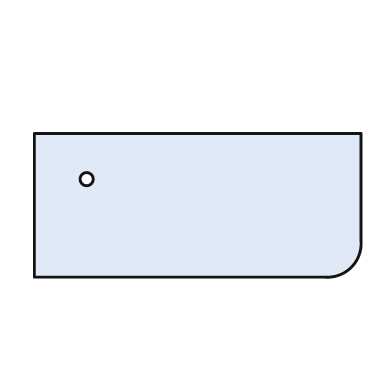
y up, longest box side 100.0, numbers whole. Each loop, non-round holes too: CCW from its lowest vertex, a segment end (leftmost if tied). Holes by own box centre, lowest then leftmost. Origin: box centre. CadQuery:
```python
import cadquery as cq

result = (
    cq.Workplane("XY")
    .moveTo(-50.0, -22.0)
    .lineTo(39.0, -22.0)
    .threePointArc((47.0, -19.0), (50.0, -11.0))
    .lineTo(50.0, 22.0)
    .lineTo(-50.0, 22.0)
    .close()
    .moveTo(-34.0, 8.0)
    .circle(2.0)
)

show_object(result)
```